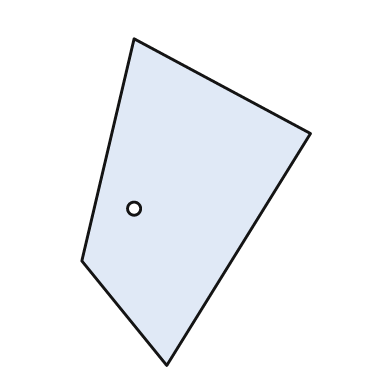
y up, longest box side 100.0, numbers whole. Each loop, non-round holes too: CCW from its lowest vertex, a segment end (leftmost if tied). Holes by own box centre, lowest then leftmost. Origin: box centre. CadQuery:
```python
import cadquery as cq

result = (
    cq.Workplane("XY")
    .moveTo(-9.0, -50.0)
    .lineTo(35.0, 21.0)
    .lineTo(-19.0, 50.0)
    .lineTo(-35.0, -18.0)
    .close()
    .moveTo(-19.0, -2.0)
    .circle(2.0)
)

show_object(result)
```